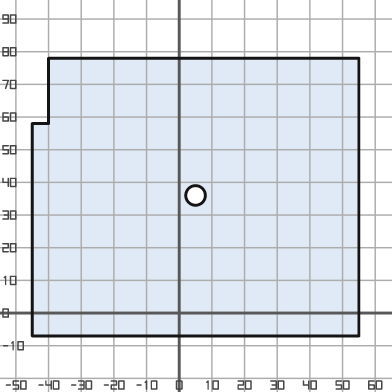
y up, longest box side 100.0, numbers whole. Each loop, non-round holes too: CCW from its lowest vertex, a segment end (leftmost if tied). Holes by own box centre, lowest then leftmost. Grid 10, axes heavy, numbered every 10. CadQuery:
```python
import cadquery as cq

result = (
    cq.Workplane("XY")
    .moveTo(-45.0, -7.0)
    .lineTo(55.0, -7.0)
    .lineTo(55.0, 78.0)
    .lineTo(-40.0, 78.0)
    .lineTo(-40.0, 58.0)
    .lineTo(-45.0, 58.0)
    .close()
    .moveTo(5.0, 36.0)
    .circle(3.0)
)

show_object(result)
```